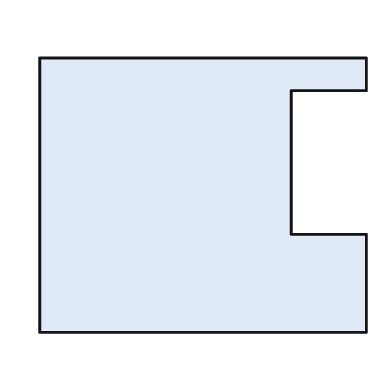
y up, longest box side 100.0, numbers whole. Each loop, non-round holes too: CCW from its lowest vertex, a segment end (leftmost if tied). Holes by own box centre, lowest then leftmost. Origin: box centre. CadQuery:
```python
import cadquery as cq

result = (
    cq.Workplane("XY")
    .moveTo(-50.0, -42.0)
    .lineTo(50.0, -42.0)
    .lineTo(50.0, -12.0)
    .lineTo(27.0, -12.0)
    .lineTo(27.0, 32.0)
    .lineTo(50.0, 32.0)
    .lineTo(50.0, 42.0)
    .lineTo(-50.0, 42.0)
    .close()
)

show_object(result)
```